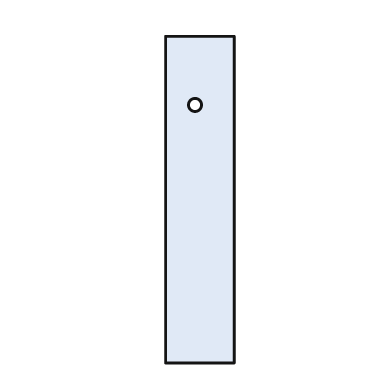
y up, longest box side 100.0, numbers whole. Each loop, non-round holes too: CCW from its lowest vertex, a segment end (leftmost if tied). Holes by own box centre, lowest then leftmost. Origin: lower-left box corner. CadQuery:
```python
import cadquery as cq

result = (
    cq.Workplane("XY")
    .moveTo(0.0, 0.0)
    .lineTo(21.0, 0.0)
    .lineTo(21.0, 100.0)
    .lineTo(0.0, 100.0)
    .close()
    .moveTo(9.0, 79.0)
    .circle(2.0)
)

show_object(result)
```